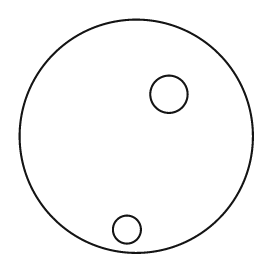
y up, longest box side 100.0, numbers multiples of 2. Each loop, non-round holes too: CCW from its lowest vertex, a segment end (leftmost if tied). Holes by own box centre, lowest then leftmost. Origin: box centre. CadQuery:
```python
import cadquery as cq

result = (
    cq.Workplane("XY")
    .moveTo(0.0, 0.0)
    .circle(50.0)
    .moveTo(-4.0, -40.0)
    .circle(6.0)
    .moveTo(14.0, 18.0)
    .circle(8.0)
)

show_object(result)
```